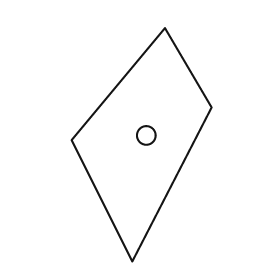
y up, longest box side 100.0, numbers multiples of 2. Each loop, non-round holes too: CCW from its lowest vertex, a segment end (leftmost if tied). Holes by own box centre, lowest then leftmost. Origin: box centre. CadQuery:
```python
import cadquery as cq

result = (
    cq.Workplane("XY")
    .moveTo(-4.0, -50.0)
    .lineTo(30.0, 16.0)
    .lineTo(10.0, 50.0)
    .lineTo(-30.0, 2.0)
    .close()
    .moveTo(2.0, 4.0)
    .circle(4.0)
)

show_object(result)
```